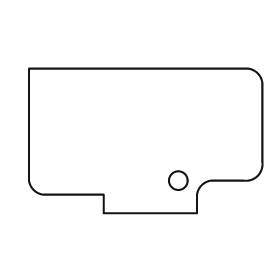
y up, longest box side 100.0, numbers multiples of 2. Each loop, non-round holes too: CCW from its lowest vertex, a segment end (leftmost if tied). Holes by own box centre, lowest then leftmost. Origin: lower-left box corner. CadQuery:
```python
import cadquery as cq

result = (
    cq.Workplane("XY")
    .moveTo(32.0, 0.0)
    .lineTo(72.0, 0.0)
    .lineTo(72.0, 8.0)
    .threePointArc((74.0, 12.0), (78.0, 14.0))
    .lineTo(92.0, 14.0)
    .threePointArc((98.0, 16.0), (100.0, 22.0))
    .lineTo(100.0, 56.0)
    .threePointArc((98.0, 60.0), (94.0, 62.0))
    .lineTo(0.0, 62.0)
    .lineTo(0.0, 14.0)
    .threePointArc((2.0, 10.0), (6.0, 8.0))
    .lineTo(32.0, 8.0)
    .close()
    .moveTo(64.0, 14.0)
    .circle(4.0)
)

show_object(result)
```